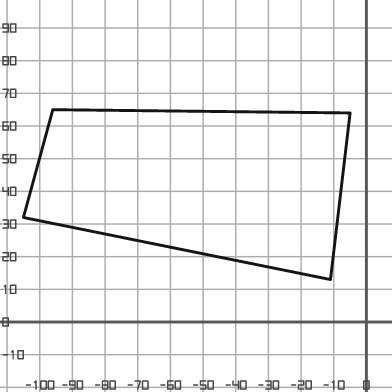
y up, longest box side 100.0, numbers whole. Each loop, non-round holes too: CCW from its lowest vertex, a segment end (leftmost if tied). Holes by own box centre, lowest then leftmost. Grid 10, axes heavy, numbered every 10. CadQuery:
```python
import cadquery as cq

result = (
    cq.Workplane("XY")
    .moveTo(-11.0, 13.0)
    .lineTo(-5.0, 64.0)
    .lineTo(-96.0, 65.0)
    .lineTo(-105.0, 32.0)
    .close()
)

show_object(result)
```